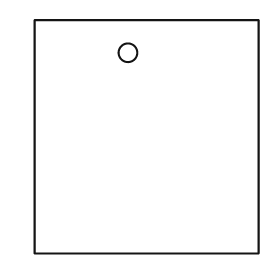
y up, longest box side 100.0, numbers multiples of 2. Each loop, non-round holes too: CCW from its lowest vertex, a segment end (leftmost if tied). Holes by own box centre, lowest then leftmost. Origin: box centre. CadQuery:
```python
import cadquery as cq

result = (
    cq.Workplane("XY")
    .moveTo(-48.0, -50.0)
    .lineTo(48.0, -50.0)
    .lineTo(48.0, 50.0)
    .lineTo(-48.0, 50.0)
    .close()
    .moveTo(-8.0, 36.0)
    .circle(4.0)
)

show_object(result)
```